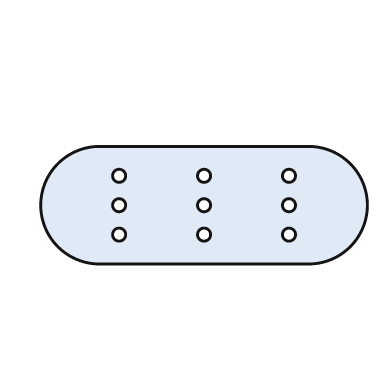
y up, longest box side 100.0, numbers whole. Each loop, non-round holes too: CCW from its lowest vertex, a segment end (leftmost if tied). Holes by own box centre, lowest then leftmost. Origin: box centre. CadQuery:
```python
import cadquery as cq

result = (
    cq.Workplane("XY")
    .moveTo(-32.0, -18.0)
    .lineTo(32.0, -18.0)
    .threePointArc((50.0, 0.0), (32.0, 18.0))
    .lineTo(-32.0, 18.0)
    .threePointArc((-50.0, 0.0), (-32.0, -18.0))
    .close()
    .moveTo(-26.0, -9.0)
    .circle(2.0)
    .moveTo(0.0, -9.0)
    .circle(2.0)
    .moveTo(26.0, -9.0)
    .circle(2.0)
    .moveTo(-26.0, 0.0)
    .circle(2.0)
    .moveTo(0.0, 0.0)
    .circle(2.0)
    .moveTo(26.0, 0.0)
    .circle(2.0)
    .moveTo(-26.0, 9.0)
    .circle(2.0)
    .moveTo(0.0, 9.0)
    .circle(2.0)
    .moveTo(26.0, 9.0)
    .circle(2.0)
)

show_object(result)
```